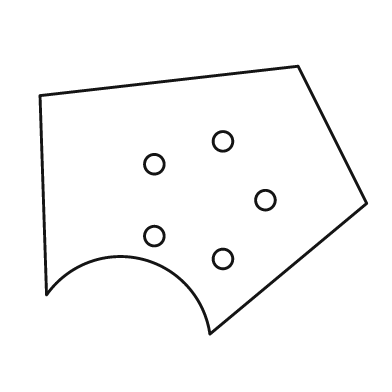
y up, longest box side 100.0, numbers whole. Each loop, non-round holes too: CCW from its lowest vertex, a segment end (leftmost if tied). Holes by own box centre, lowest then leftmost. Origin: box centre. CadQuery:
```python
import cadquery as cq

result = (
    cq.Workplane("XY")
    .moveTo(2.0, -41.0)
    .lineTo(50.0, -1.0)
    .lineTo(29.0, 41.0)
    .lineTo(-50.0, 32.0)
    .lineTo(-48.0, -29.0)
    .threePointArc((-19.0, -18.0), (2.0, -41.0))
    .close()
    .moveTo(6.0, -18.0)
    .circle(3.0)
    .moveTo(-15.0, -11.0)
    .circle(3.0)
    .moveTo(19.0, 0.0)
    .circle(3.0)
    .moveTo(-15.0, 11.0)
    .circle(3.0)
    .moveTo(6.0, 18.0)
    .circle(3.0)
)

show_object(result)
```